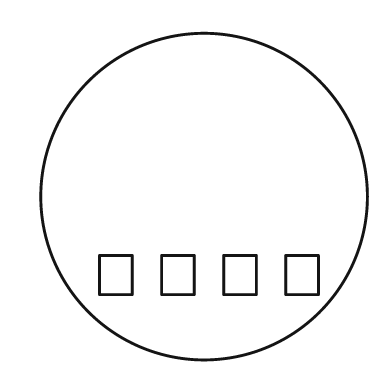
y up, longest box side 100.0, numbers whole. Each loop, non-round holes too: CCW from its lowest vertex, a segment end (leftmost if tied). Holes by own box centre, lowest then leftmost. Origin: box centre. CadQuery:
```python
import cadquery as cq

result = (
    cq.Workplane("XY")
    .moveTo(0.0, 0.0)
    .circle(50.0)
    .moveTo(-32.0, -30.0)
    .lineTo(-22.0, -30.0)
    .lineTo(-22.0, -18.0)
    .lineTo(-32.0, -18.0)
    .close()
    .moveTo(-13.0, -30.0)
    .lineTo(-3.0, -30.0)
    .lineTo(-3.0, -18.0)
    .lineTo(-13.0, -18.0)
    .close()
    .moveTo(6.0, -30.0)
    .lineTo(16.0, -30.0)
    .lineTo(16.0, -18.0)
    .lineTo(6.0, -18.0)
    .close()
    .moveTo(25.0, -30.0)
    .lineTo(35.0, -30.0)
    .lineTo(35.0, -18.0)
    .lineTo(25.0, -18.0)
    .close()
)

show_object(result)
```